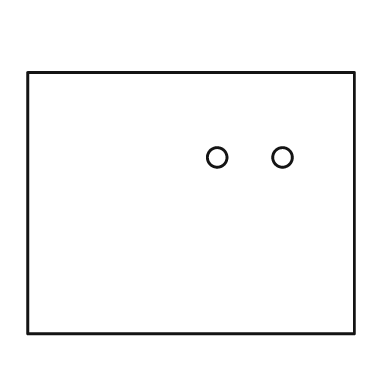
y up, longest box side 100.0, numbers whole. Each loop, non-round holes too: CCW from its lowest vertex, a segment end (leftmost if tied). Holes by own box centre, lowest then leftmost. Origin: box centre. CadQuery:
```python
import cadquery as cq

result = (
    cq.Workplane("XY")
    .moveTo(-50.0, -40.0)
    .lineTo(50.0, -40.0)
    .lineTo(50.0, 40.0)
    .lineTo(-50.0, 40.0)
    .close()
    .moveTo(8.0, 14.0)
    .circle(3.0)
    .moveTo(28.0, 14.0)
    .circle(3.0)
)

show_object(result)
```